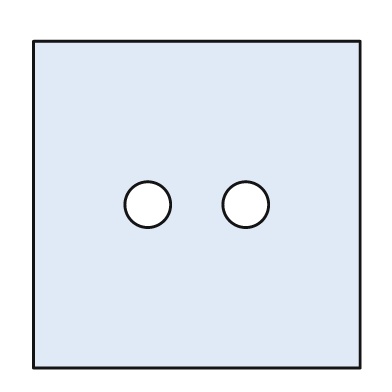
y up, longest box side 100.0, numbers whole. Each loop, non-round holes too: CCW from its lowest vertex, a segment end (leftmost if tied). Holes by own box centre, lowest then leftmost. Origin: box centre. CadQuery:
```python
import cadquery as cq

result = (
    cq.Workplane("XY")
    .moveTo(-50.0, -50.0)
    .lineTo(50.0, -50.0)
    .lineTo(50.0, 50.0)
    .lineTo(-50.0, 50.0)
    .close()
    .moveTo(-15.0, 0.0)
    .circle(7.0)
    .moveTo(15.0, 0.0)
    .circle(7.0)
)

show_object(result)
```